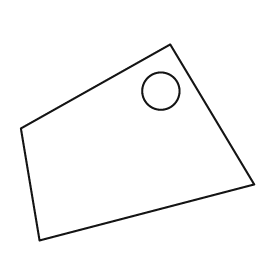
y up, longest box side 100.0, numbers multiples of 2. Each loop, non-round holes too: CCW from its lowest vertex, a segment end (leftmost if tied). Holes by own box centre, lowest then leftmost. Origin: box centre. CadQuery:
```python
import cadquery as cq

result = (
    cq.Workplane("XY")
    .moveTo(-42.0, -42.0)
    .lineTo(50.0, -18.0)
    .lineTo(14.0, 42.0)
    .lineTo(-50.0, 6.0)
    .close()
    .moveTo(10.0, 22.0)
    .circle(8.0)
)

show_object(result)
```